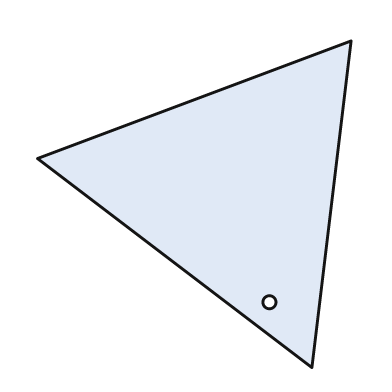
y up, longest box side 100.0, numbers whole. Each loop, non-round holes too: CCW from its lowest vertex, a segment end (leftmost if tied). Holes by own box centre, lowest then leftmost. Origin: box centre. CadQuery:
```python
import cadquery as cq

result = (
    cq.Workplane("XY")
    .moveTo(36.0, -50.0)
    .lineTo(48.0, 50.0)
    .lineTo(-48.0, 14.0)
    .close()
    .moveTo(23.0, -30.0)
    .circle(2.0)
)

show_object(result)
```